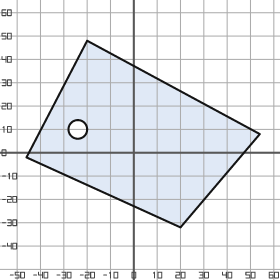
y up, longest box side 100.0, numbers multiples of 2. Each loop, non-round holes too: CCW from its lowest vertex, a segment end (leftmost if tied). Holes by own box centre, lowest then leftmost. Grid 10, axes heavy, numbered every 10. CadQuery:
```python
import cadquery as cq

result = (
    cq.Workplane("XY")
    .moveTo(20.0, -32.0)
    .lineTo(54.0, 8.0)
    .lineTo(-20.0, 48.0)
    .lineTo(-46.0, -2.0)
    .close()
    .moveTo(-24.0, 10.0)
    .circle(4.0)
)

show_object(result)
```